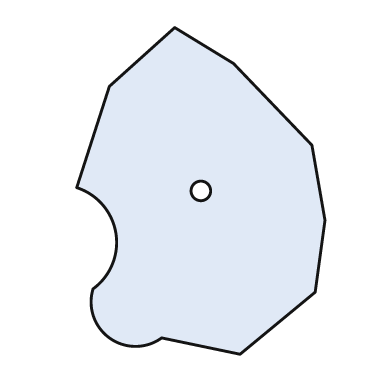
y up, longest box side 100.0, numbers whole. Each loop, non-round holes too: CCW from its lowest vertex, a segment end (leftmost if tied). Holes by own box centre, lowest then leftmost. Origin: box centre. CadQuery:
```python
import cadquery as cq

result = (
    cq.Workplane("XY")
    .moveTo(12.0, -50.0)
    .lineTo(35.0, -31.0)
    .lineTo(38.0, -9.0)
    .lineTo(34.0, 14.0)
    .lineTo(10.0, 39.0)
    .lineTo(-8.0, 50.0)
    .lineTo(-28.0, 32.0)
    .lineTo(-38.0, 1.0)
    .threePointArc((-26.0, -13.0), (-33.0, -30.0))
    .threePointArc((-28.0, -45.0), (-12.0, -45.0))
    .close()
    .moveTo(0.0, 0.0)
    .circle(3.0)
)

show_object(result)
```